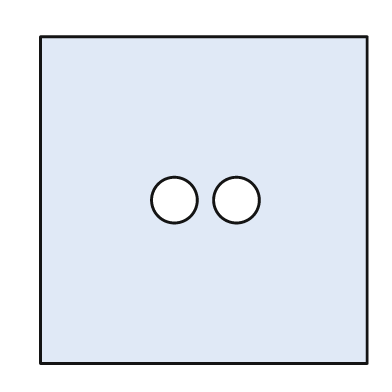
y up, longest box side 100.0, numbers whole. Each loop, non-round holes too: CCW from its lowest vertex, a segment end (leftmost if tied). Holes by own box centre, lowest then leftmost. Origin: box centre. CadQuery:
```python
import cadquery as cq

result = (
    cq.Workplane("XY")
    .moveTo(-50.0, -50.0)
    .lineTo(50.0, -50.0)
    .lineTo(50.0, 50.0)
    .lineTo(-50.0, 50.0)
    .close()
    .moveTo(-9.0, 0.0)
    .circle(7.0)
    .moveTo(10.0, 0.0)
    .circle(7.0)
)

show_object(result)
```